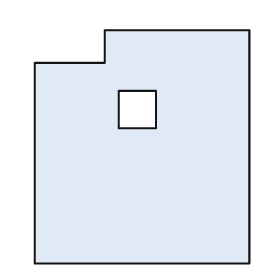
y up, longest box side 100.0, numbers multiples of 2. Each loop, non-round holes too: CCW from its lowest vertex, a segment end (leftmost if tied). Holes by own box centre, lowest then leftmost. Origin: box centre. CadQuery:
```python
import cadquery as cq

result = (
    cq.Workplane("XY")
    .moveTo(-46.0, -50.0)
    .lineTo(46.0, -50.0)
    .lineTo(46.0, 50.0)
    .lineTo(-16.0, 50.0)
    .lineTo(-16.0, 36.0)
    .lineTo(-46.0, 36.0)
    .close()
    .moveTo(-10.0, 8.0)
    .lineTo(6.0, 8.0)
    .lineTo(6.0, 24.0)
    .lineTo(-10.0, 24.0)
    .close()
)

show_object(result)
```